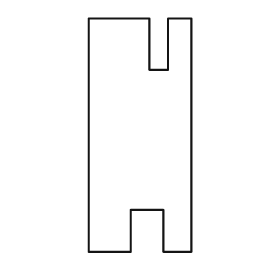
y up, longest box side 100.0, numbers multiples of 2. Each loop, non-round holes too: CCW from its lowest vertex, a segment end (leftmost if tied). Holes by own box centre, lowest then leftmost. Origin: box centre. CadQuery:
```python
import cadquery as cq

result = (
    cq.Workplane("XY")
    .moveTo(-22.0, -50.0)
    .lineTo(-4.0, -50.0)
    .lineTo(-4.0, -32.0)
    .lineTo(10.0, -32.0)
    .lineTo(10.0, -50.0)
    .lineTo(22.0, -50.0)
    .lineTo(22.0, 50.0)
    .lineTo(12.0, 50.0)
    .lineTo(12.0, 28.0)
    .lineTo(4.0, 28.0)
    .lineTo(4.0, 50.0)
    .lineTo(-22.0, 50.0)
    .close()
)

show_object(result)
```